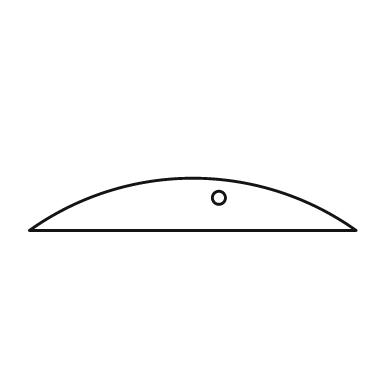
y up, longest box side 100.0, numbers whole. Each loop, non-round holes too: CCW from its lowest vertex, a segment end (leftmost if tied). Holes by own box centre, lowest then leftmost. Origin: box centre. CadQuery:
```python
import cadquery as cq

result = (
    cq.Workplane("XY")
    .moveTo(-50.0, -8.0)
    .lineTo(50.0, -8.0)
    .threePointArc((0.0, 8.0), (-50.0, -8.0))
    .close()
    .moveTo(8.0, 2.0)
    .circle(2.0)
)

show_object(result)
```